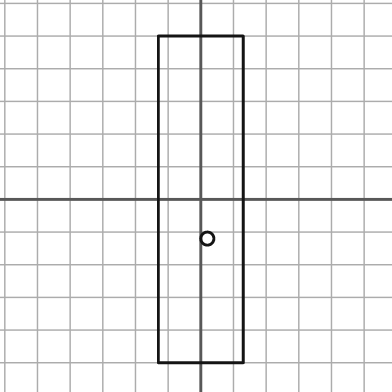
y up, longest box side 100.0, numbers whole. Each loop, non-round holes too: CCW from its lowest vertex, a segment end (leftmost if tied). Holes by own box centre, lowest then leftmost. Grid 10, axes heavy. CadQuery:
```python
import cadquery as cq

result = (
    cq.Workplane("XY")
    .moveTo(-13.0, -50.0)
    .lineTo(13.0, -50.0)
    .lineTo(13.0, 50.0)
    .lineTo(-13.0, 50.0)
    .close()
    .moveTo(2.0, -12.0)
    .circle(2.0)
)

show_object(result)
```